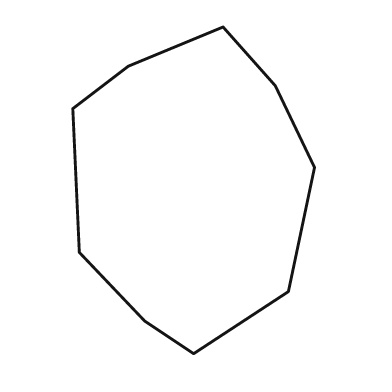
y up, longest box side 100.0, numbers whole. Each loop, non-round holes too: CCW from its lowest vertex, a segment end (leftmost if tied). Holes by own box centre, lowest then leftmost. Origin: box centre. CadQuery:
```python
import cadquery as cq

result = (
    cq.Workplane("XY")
    .moveTo(0.0, -50.0)
    .lineTo(29.0, -31.0)
    .lineTo(37.0, 7.0)
    .lineTo(25.0, 32.0)
    .lineTo(9.0, 50.0)
    .lineTo(-20.0, 38.0)
    .lineTo(-37.0, 25.0)
    .lineTo(-35.0, -19.0)
    .lineTo(-15.0, -40.0)
    .close()
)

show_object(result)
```